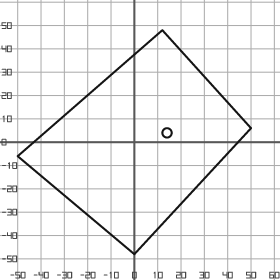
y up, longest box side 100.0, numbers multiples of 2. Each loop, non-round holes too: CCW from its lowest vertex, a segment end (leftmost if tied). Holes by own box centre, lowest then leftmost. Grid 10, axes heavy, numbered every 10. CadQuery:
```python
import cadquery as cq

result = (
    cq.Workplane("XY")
    .moveTo(0.0, -48.0)
    .lineTo(50.0, 6.0)
    .lineTo(12.0, 48.0)
    .lineTo(-50.0, -6.0)
    .close()
    .moveTo(14.0, 4.0)
    .circle(2.0)
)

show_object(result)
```